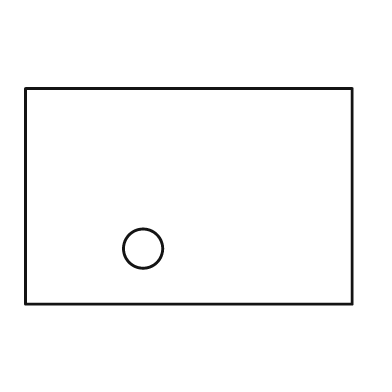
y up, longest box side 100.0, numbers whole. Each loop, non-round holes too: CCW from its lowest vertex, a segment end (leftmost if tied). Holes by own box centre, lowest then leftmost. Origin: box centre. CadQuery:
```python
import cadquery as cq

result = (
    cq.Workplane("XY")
    .moveTo(-50.0, -33.0)
    .lineTo(50.0, -33.0)
    .lineTo(50.0, 33.0)
    .lineTo(-50.0, 33.0)
    .close()
    .moveTo(-14.0, -16.0)
    .circle(6.0)
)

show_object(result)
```